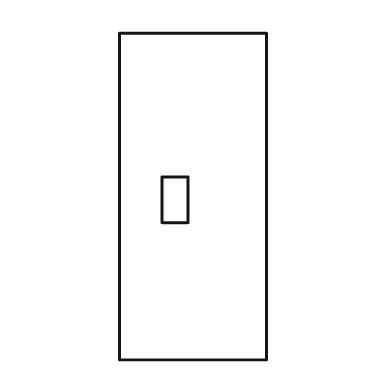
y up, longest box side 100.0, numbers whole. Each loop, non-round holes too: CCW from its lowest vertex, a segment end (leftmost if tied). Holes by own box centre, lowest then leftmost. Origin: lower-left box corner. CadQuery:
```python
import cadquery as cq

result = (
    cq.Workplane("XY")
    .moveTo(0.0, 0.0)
    .lineTo(45.0, 0.0)
    .lineTo(45.0, 100.0)
    .lineTo(0.0, 100.0)
    .close()
    .moveTo(13.0, 42.0)
    .lineTo(21.0, 42.0)
    .lineTo(21.0, 56.0)
    .lineTo(13.0, 56.0)
    .close()
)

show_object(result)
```